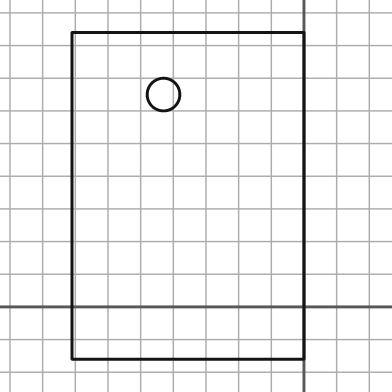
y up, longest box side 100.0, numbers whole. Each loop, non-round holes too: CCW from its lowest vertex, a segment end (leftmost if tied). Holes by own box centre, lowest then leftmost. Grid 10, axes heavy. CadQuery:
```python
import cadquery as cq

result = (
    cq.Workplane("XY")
    .moveTo(-71.0, -16.0)
    .lineTo(0.0, -16.0)
    .lineTo(0.0, 84.0)
    .lineTo(-71.0, 84.0)
    .close()
    .moveTo(-43.0, 65.0)
    .circle(5.0)
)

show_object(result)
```